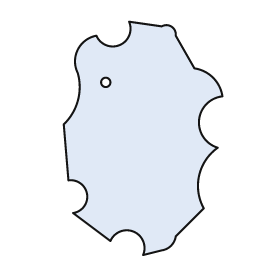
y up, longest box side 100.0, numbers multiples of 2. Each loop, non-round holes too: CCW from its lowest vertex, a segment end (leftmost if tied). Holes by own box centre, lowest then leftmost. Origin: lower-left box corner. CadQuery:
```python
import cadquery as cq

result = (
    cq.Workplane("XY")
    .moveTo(34.0, 0.0)
    .lineTo(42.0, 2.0)
    .threePointArc((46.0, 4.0), (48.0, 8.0))
    .lineTo(60.0, 20.0)
    .threePointArc((58.0, 34.0), (66.0, 46.0))
    .threePointArc((58.0, 58.0), (68.0, 68.0))
    .threePointArc((64.0, 76.0), (56.0, 80.0))
    .lineTo(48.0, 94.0)
    .threePointArc((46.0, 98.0), (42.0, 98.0))
    .lineTo(28.0, 100.0)
    .threePointArc((24.0, 90.0), (14.0, 94.0))
    .threePointArc((6.0, 88.0), (6.0, 78.0))
    .threePointArc((6.0, 66.0), (0.0, 56.0))
    .lineTo(2.0, 32.0)
    .threePointArc((10.0, 26.0), (4.0, 18.0))
    .lineTo(20.0, 6.0)
    .threePointArc((30.0, 10.0), (34.0, 0.0))
    .close()
    .moveTo(18.0, 74.0)
    .circle(2.0)
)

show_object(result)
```